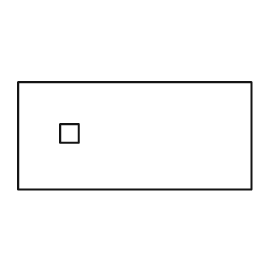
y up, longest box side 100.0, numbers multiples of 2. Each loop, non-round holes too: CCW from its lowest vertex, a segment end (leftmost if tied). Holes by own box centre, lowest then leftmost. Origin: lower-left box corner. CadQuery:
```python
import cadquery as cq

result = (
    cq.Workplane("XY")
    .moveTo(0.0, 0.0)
    .lineTo(100.0, 0.0)
    .lineTo(100.0, 46.0)
    .lineTo(0.0, 46.0)
    .close()
    .moveTo(18.0, 20.0)
    .lineTo(26.0, 20.0)
    .lineTo(26.0, 28.0)
    .lineTo(18.0, 28.0)
    .close()
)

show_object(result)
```